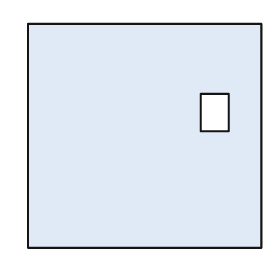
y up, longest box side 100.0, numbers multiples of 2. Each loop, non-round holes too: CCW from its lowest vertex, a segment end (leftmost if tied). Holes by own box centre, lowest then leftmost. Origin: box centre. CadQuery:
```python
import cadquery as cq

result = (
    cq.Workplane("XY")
    .moveTo(-50.0, -48.0)
    .lineTo(50.0, -48.0)
    .lineTo(50.0, 48.0)
    .lineTo(-50.0, 48.0)
    .close()
    .moveTo(24.0, 2.0)
    .lineTo(36.0, 2.0)
    .lineTo(36.0, 18.0)
    .lineTo(24.0, 18.0)
    .close()
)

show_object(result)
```